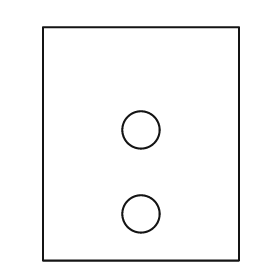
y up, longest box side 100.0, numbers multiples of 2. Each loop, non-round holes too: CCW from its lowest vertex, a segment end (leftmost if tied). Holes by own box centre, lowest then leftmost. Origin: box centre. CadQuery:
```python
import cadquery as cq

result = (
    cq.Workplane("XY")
    .moveTo(-42.0, -50.0)
    .lineTo(42.0, -50.0)
    .lineTo(42.0, 50.0)
    .lineTo(-42.0, 50.0)
    .close()
    .moveTo(0.0, -30.0)
    .circle(8.0)
    .moveTo(0.0, 6.0)
    .circle(8.0)
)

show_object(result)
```